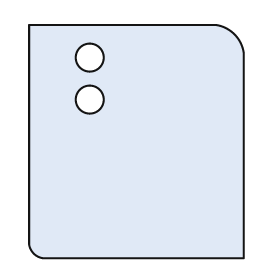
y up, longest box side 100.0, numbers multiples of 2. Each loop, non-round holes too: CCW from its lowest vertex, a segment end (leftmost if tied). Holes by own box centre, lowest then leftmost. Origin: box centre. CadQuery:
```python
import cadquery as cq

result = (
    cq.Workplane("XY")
    .moveTo(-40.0, -50.0)
    .lineTo(46.0, -50.0)
    .lineTo(46.0, 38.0)
    .threePointArc((42.0, 46.0), (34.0, 50.0))
    .lineTo(-46.0, 50.0)
    .lineTo(-46.0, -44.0)
    .threePointArc((-44.0, -48.0), (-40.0, -50.0))
    .close()
    .moveTo(-20.0, 18.0)
    .circle(6.0)
    .moveTo(-20.0, 36.0)
    .circle(6.0)
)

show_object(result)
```